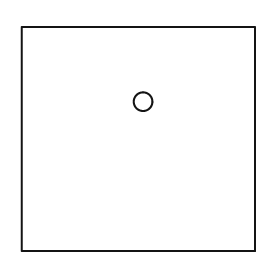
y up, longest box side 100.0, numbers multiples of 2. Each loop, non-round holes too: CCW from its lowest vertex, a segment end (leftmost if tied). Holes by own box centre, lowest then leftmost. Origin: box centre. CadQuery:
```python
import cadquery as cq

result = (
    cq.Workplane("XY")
    .moveTo(-50.0, -48.0)
    .lineTo(50.0, -48.0)
    .lineTo(50.0, 48.0)
    .lineTo(-50.0, 48.0)
    .close()
    .moveTo(2.0, 16.0)
    .circle(4.0)
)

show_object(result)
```